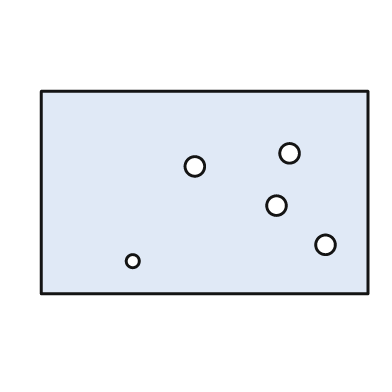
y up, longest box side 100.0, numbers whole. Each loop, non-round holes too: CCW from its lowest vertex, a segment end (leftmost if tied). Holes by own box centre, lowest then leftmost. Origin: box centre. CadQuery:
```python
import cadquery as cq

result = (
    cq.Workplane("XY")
    .moveTo(-50.0, -31.0)
    .lineTo(50.0, -31.0)
    .lineTo(50.0, 31.0)
    .lineTo(-50.0, 31.0)
    .close()
    .moveTo(-22.0, -21.0)
    .circle(2.0)
    .moveTo(37.0, -16.0)
    .circle(3.0)
    .moveTo(22.0, -4.0)
    .circle(3.0)
    .moveTo(-3.0, 8.0)
    .circle(3.0)
    .moveTo(26.0, 12.0)
    .circle(3.0)
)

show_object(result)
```